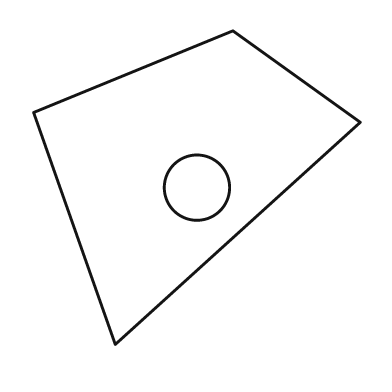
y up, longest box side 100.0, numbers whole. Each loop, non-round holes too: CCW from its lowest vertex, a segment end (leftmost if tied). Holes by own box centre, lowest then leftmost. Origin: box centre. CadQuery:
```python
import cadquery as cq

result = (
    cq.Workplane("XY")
    .moveTo(-25.0, -48.0)
    .lineTo(50.0, 20.0)
    .lineTo(11.0, 48.0)
    .lineTo(-50.0, 23.0)
    .close()
    .moveTo(0.0, 0.0)
    .circle(10.0)
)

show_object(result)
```